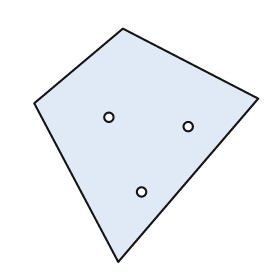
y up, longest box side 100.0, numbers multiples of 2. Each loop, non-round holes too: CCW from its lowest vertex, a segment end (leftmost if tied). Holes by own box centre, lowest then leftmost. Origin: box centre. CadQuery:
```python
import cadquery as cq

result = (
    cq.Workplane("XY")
    .moveTo(-12.0, -50.0)
    .lineTo(48.0, 20.0)
    .lineTo(-10.0, 50.0)
    .lineTo(-48.0, 18.0)
    .close()
    .moveTo(-2.0, -20.0)
    .circle(2.0)
    .moveTo(18.0, 8.0)
    .circle(2.0)
    .moveTo(-16.0, 12.0)
    .circle(2.0)
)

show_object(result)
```